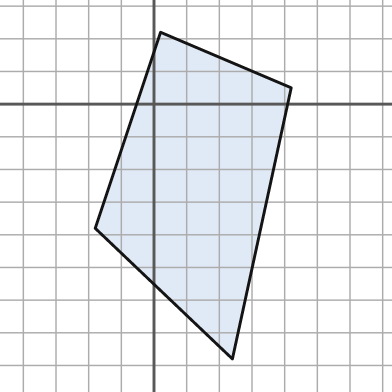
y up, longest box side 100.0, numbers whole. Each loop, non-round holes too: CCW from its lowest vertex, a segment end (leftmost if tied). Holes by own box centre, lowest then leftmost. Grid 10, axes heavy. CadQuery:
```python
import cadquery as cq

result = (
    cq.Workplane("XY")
    .moveTo(24.0, -78.0)
    .lineTo(42.0, 5.0)
    .lineTo(2.0, 22.0)
    .lineTo(-18.0, -38.0)
    .close()
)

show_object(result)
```